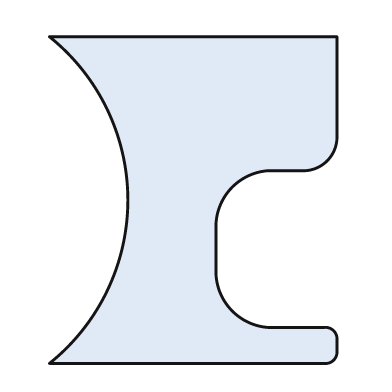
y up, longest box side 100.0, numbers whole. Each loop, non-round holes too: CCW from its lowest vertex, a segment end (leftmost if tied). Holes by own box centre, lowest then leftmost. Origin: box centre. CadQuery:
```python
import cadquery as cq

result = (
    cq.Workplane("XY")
    .moveTo(-44.0, -50.0)
    .lineTo(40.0, -50.0)
    .threePointArc((43.0, -49.0), (44.0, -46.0))
    .lineTo(44.0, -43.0)
    .threePointArc((43.0, -40.0), (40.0, -39.0))
    .lineTo(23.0, -39.0)
    .threePointArc((12.0, -34.0), (7.0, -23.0))
    .lineTo(7.0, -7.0)
    .threePointArc((12.0, 4.0), (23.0, 9.0))
    .lineTo(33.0, 9.0)
    .threePointArc((41.0, 12.0), (44.0, 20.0))
    .lineTo(44.0, 50.0)
    .lineTo(-44.0, 50.0)
    .threePointArc((-20.0, 0.0), (-44.0, -50.0))
    .close()
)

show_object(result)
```